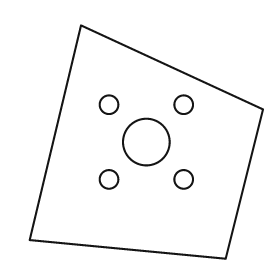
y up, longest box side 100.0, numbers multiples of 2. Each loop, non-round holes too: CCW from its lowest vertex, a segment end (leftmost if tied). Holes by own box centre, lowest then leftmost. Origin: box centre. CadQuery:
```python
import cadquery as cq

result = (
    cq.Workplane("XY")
    .moveTo(34.0, -50.0)
    .lineTo(50.0, 14.0)
    .lineTo(-28.0, 50.0)
    .lineTo(-50.0, -42.0)
    .close()
    .moveTo(-16.0, -16.0)
    .circle(4.0)
    .moveTo(16.0, -16.0)
    .circle(4.0)
    .moveTo(0.0, 0.0)
    .circle(10.0)
    .moveTo(-16.0, 16.0)
    .circle(4.0)
    .moveTo(16.0, 16.0)
    .circle(4.0)
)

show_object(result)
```